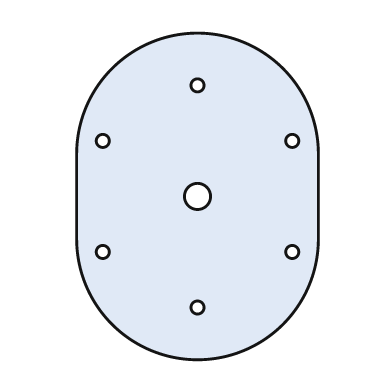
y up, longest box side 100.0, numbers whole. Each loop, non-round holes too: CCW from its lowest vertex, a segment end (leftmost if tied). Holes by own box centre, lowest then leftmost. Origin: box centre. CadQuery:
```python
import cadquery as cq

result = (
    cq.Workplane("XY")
    .moveTo(-37.0, -13.0)
    .threePointArc((0.0, -50.0), (37.0, -13.0))
    .lineTo(37.0, 13.0)
    .threePointArc((0.0, 50.0), (-37.0, 13.0))
    .close()
    .moveTo(0.0, -34.0)
    .circle(2.0)
    .moveTo(-29.0, -17.0)
    .circle(2.0)
    .moveTo(29.0, -17.0)
    .circle(2.0)
    .moveTo(0.0, 0.0)
    .circle(4.0)
    .moveTo(-29.0, 17.0)
    .circle(2.0)
    .moveTo(29.0, 17.0)
    .circle(2.0)
    .moveTo(0.0, 34.0)
    .circle(2.0)
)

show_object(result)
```